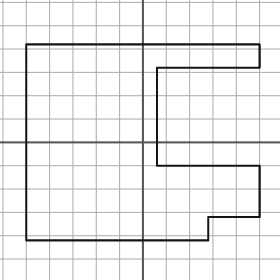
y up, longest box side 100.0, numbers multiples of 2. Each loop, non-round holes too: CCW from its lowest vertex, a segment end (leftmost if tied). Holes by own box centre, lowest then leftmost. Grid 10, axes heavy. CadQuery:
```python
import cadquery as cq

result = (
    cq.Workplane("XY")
    .moveTo(-50.0, -42.0)
    .lineTo(28.0, -42.0)
    .lineTo(28.0, -32.0)
    .lineTo(50.0, -32.0)
    .lineTo(50.0, -10.0)
    .lineTo(6.0, -10.0)
    .lineTo(6.0, 32.0)
    .lineTo(50.0, 32.0)
    .lineTo(50.0, 42.0)
    .lineTo(-50.0, 42.0)
    .close()
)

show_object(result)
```